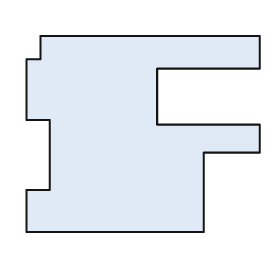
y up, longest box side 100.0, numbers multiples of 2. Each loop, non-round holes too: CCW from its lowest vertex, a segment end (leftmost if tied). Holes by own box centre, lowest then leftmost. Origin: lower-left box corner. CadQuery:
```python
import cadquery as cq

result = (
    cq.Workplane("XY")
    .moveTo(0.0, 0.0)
    .lineTo(76.0, 0.0)
    .lineTo(76.0, 34.0)
    .lineTo(100.0, 34.0)
    .lineTo(100.0, 46.0)
    .lineTo(56.0, 46.0)
    .lineTo(56.0, 70.0)
    .lineTo(100.0, 70.0)
    .lineTo(100.0, 84.0)
    .lineTo(6.0, 84.0)
    .lineTo(6.0, 74.0)
    .lineTo(0.0, 74.0)
    .lineTo(0.0, 48.0)
    .lineTo(10.0, 48.0)
    .lineTo(10.0, 18.0)
    .lineTo(0.0, 18.0)
    .close()
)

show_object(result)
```